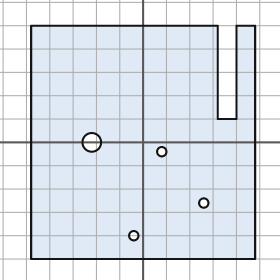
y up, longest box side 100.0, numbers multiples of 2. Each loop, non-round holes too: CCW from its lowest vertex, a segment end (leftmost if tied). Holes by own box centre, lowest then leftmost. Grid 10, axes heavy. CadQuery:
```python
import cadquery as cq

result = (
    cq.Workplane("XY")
    .moveTo(-48.0, -50.0)
    .lineTo(48.0, -50.0)
    .lineTo(48.0, 50.0)
    .lineTo(40.0, 50.0)
    .lineTo(40.0, 10.0)
    .lineTo(32.0, 10.0)
    .lineTo(32.0, 50.0)
    .lineTo(-48.0, 50.0)
    .close()
    .moveTo(-4.0, -40.0)
    .circle(2.0)
    .moveTo(26.0, -26.0)
    .circle(2.0)
    .moveTo(8.0, -4.0)
    .circle(2.0)
    .moveTo(-22.0, 0.0)
    .circle(4.0)
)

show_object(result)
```